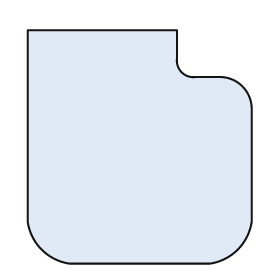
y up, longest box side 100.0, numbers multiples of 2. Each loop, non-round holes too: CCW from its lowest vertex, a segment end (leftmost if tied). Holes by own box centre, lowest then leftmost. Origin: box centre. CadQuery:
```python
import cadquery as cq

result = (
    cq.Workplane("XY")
    .moveTo(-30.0, -50.0)
    .lineTo(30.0, -50.0)
    .threePointArc((42.0, -44.0), (48.0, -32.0))
    .lineTo(48.0, 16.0)
    .threePointArc((44.0, 26.0), (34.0, 30.0))
    .lineTo(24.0, 30.0)
    .threePointArc((18.0, 32.0), (16.0, 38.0))
    .lineTo(16.0, 50.0)
    .lineTo(-48.0, 50.0)
    .lineTo(-48.0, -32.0)
    .threePointArc((-42.0, -44.0), (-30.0, -50.0))
    .close()
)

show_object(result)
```